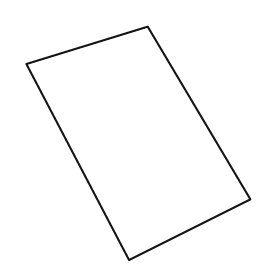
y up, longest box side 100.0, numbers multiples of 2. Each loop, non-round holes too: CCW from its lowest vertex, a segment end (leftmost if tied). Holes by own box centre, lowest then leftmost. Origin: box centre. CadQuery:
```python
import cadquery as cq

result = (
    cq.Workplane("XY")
    .moveTo(-4.0, -50.0)
    .lineTo(48.0, -24.0)
    .lineTo(4.0, 50.0)
    .lineTo(-48.0, 34.0)
    .close()
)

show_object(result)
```